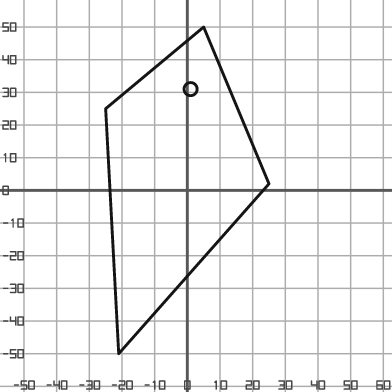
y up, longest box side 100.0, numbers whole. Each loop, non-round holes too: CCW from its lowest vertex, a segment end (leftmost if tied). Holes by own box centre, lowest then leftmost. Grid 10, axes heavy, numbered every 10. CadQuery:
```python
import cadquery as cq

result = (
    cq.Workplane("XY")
    .moveTo(-21.0, -50.0)
    .lineTo(25.0, 2.0)
    .lineTo(5.0, 50.0)
    .lineTo(-25.0, 25.0)
    .close()
    .moveTo(1.0, 31.0)
    .circle(2.0)
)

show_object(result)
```